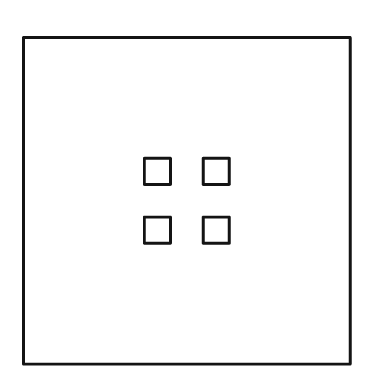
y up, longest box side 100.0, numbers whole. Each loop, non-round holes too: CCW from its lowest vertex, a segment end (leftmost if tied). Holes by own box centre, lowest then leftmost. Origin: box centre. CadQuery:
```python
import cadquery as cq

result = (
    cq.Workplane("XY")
    .moveTo(-50.0, -50.0)
    .lineTo(50.0, -50.0)
    .lineTo(50.0, 50.0)
    .lineTo(-50.0, 50.0)
    .close()
    .moveTo(-13.0, -13.0)
    .lineTo(-5.0, -13.0)
    .lineTo(-5.0, -5.0)
    .lineTo(-13.0, -5.0)
    .close()
    .moveTo(5.0, -13.0)
    .lineTo(13.0, -13.0)
    .lineTo(13.0, -5.0)
    .lineTo(5.0, -5.0)
    .close()
    .moveTo(-13.0, 5.0)
    .lineTo(-5.0, 5.0)
    .lineTo(-5.0, 13.0)
    .lineTo(-13.0, 13.0)
    .close()
    .moveTo(5.0, 5.0)
    .lineTo(13.0, 5.0)
    .lineTo(13.0, 13.0)
    .lineTo(5.0, 13.0)
    .close()
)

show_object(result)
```